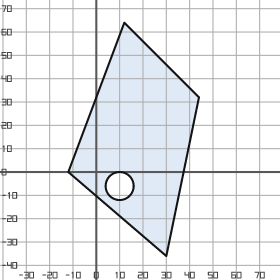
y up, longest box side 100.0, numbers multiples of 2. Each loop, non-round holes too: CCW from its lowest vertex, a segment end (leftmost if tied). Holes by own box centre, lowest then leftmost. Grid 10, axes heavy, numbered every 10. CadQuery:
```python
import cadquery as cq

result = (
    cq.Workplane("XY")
    .moveTo(30.0, -36.0)
    .lineTo(44.0, 32.0)
    .lineTo(12.0, 64.0)
    .lineTo(-12.0, 0.0)
    .close()
    .moveTo(10.0, -6.0)
    .circle(6.0)
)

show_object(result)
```